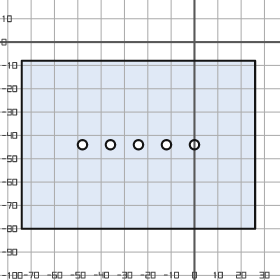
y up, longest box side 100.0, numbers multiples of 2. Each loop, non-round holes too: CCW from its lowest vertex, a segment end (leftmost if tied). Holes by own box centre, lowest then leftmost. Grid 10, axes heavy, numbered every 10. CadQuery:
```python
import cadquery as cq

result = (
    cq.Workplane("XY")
    .moveTo(-74.0, -80.0)
    .lineTo(26.0, -80.0)
    .lineTo(26.0, -8.0)
    .lineTo(-74.0, -8.0)
    .close()
    .moveTo(-48.0, -44.0)
    .circle(2.0)
    .moveTo(-36.0, -44.0)
    .circle(2.0)
    .moveTo(-24.0, -44.0)
    .circle(2.0)
    .moveTo(-12.0, -44.0)
    .circle(2.0)
    .moveTo(0.0, -44.0)
    .circle(2.0)
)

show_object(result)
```